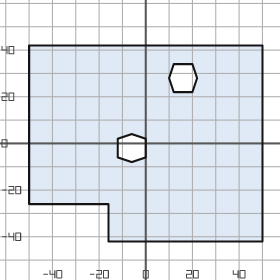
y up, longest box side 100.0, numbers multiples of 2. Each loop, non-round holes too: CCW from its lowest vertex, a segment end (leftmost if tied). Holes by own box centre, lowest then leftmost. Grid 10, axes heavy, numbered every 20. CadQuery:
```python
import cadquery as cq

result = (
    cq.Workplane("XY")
    .moveTo(-16.0, -42.0)
    .lineTo(50.0, -42.0)
    .lineTo(50.0, 42.0)
    .lineTo(-50.0, 42.0)
    .lineTo(-50.0, -26.0)
    .lineTo(-16.0, -26.0)
    .close()
    .moveTo(-6.0, -8.0)
    .lineTo(0.0, -6.0)
    .lineTo(0.0, 2.0)
    .lineTo(-6.0, 4.0)
    .lineTo(-12.0, 2.0)
    .lineTo(-12.0, -6.0)
    .close()
    .moveTo(12.0, 22.0)
    .lineTo(20.0, 22.0)
    .lineTo(22.0, 28.0)
    .lineTo(20.0, 34.0)
    .lineTo(12.0, 34.0)
    .lineTo(10.0, 28.0)
    .close()
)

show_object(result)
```